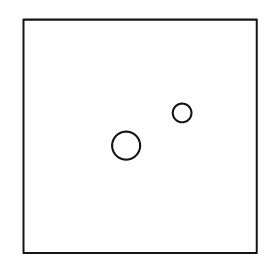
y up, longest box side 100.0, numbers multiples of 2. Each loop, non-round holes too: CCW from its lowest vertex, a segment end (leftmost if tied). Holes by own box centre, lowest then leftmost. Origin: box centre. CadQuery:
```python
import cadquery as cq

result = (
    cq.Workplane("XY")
    .moveTo(-50.0, -50.0)
    .lineTo(50.0, -50.0)
    .lineTo(50.0, 50.0)
    .lineTo(-50.0, 50.0)
    .close()
    .moveTo(-6.0, -4.0)
    .circle(6.0)
    .moveTo(18.0, 10.0)
    .circle(4.0)
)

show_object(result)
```